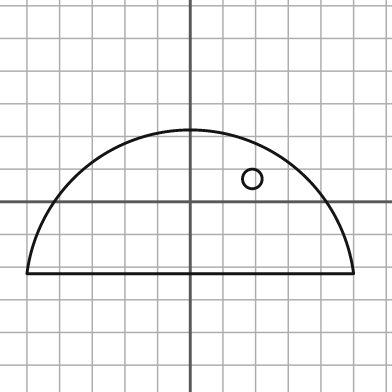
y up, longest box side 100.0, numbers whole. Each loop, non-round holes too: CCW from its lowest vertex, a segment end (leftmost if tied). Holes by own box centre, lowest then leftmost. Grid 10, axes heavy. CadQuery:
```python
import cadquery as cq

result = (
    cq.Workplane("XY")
    .moveTo(-50.0, -22.0)
    .lineTo(50.0, -22.0)
    .threePointArc((0.0, 22.0), (-50.0, -22.0))
    .close()
    .moveTo(19.0, 7.0)
    .circle(3.0)
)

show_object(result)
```